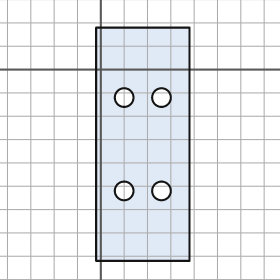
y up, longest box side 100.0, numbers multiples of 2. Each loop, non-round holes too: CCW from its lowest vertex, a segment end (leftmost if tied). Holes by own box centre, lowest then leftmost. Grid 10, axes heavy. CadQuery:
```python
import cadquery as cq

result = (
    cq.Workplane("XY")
    .moveTo(-2.0, -82.0)
    .lineTo(38.0, -82.0)
    .lineTo(38.0, 18.0)
    .lineTo(-2.0, 18.0)
    .close()
    .moveTo(10.0, -52.0)
    .circle(4.0)
    .moveTo(26.0, -52.0)
    .circle(4.0)
    .moveTo(10.0, -12.0)
    .circle(4.0)
    .moveTo(26.0, -12.0)
    .circle(4.0)
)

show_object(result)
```